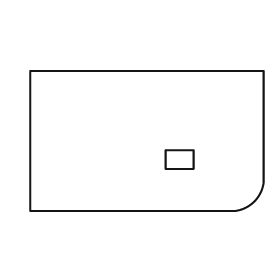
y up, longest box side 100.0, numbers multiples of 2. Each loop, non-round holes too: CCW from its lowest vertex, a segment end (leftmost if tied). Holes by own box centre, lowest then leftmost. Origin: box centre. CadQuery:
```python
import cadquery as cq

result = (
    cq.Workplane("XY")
    .moveTo(-50.0, -30.0)
    .lineTo(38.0, -30.0)
    .threePointArc((46.0, -26.0), (50.0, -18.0))
    .lineTo(50.0, 30.0)
    .lineTo(-50.0, 30.0)
    .close()
    .moveTo(8.0, -12.0)
    .lineTo(20.0, -12.0)
    .lineTo(20.0, -4.0)
    .lineTo(8.0, -4.0)
    .close()
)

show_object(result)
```